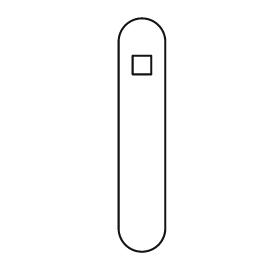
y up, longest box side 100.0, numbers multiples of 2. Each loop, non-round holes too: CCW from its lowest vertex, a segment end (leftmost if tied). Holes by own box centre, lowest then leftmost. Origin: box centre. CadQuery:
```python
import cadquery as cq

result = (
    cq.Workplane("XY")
    .moveTo(-10.0, -40.0)
    .threePointArc((0.0, -50.0), (10.0, -40.0))
    .lineTo(10.0, 40.0)
    .threePointArc((0.0, 50.0), (-10.0, 40.0))
    .close()
    .moveTo(-4.0, 26.0)
    .lineTo(4.0, 26.0)
    .lineTo(4.0, 34.0)
    .lineTo(-4.0, 34.0)
    .close()
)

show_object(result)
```